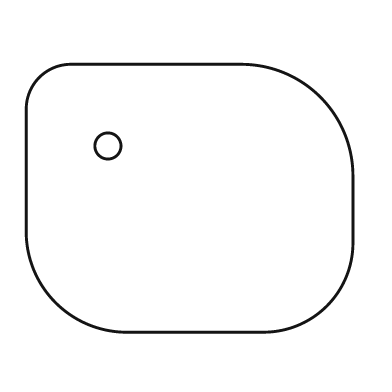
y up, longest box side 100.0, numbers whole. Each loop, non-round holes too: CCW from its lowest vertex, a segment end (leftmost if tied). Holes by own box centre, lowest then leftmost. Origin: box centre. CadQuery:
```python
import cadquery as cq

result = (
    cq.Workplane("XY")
    .moveTo(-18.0, -41.0)
    .lineTo(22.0, -41.0)
    .threePointArc((42.0, -33.0), (50.0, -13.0))
    .lineTo(50.0, 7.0)
    .threePointArc((40.0, 31.0), (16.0, 41.0))
    .lineTo(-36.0, 41.0)
    .threePointArc((-46.0, 37.0), (-50.0, 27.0))
    .lineTo(-50.0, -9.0)
    .threePointArc((-41.0, -32.0), (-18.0, -41.0))
    .close()
    .moveTo(-25.0, 16.0)
    .circle(4.0)
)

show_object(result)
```